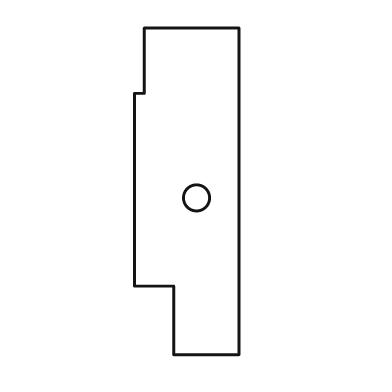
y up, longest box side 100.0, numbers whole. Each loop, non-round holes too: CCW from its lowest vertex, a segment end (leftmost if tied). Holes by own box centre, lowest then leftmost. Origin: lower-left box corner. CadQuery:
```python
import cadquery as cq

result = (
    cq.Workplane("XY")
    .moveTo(12.0, 0.0)
    .lineTo(32.0, 0.0)
    .lineTo(32.0, 100.0)
    .lineTo(3.0, 100.0)
    .lineTo(3.0, 80.0)
    .lineTo(0.0, 80.0)
    .lineTo(0.0, 21.0)
    .lineTo(12.0, 21.0)
    .close()
    .moveTo(19.0, 48.0)
    .circle(4.0)
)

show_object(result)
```